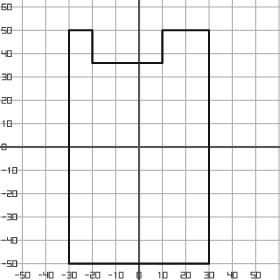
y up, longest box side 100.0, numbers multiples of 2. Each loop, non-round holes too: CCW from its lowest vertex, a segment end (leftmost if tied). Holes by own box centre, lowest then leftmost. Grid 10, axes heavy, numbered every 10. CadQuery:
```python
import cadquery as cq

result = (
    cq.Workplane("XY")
    .moveTo(-30.0, -50.0)
    .lineTo(30.0, -50.0)
    .lineTo(30.0, 50.0)
    .lineTo(10.0, 50.0)
    .lineTo(10.0, 36.0)
    .lineTo(-20.0, 36.0)
    .lineTo(-20.0, 50.0)
    .lineTo(-30.0, 50.0)
    .close()
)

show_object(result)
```